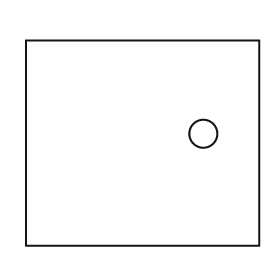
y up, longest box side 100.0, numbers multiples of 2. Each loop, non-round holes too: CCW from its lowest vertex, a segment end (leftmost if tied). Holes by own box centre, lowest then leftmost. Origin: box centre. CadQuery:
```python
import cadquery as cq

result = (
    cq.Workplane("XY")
    .moveTo(-50.0, -44.0)
    .lineTo(50.0, -44.0)
    .lineTo(50.0, 44.0)
    .lineTo(-50.0, 44.0)
    .close()
    .moveTo(26.0, 4.0)
    .circle(6.0)
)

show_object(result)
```